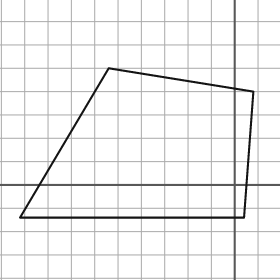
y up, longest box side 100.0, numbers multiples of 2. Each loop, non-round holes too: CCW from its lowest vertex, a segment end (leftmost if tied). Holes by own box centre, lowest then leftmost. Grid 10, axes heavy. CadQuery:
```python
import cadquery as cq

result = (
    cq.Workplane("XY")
    .moveTo(-92.0, -14.0)
    .lineTo(4.0, -14.0)
    .lineTo(8.0, 40.0)
    .lineTo(-54.0, 50.0)
    .close()
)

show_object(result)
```